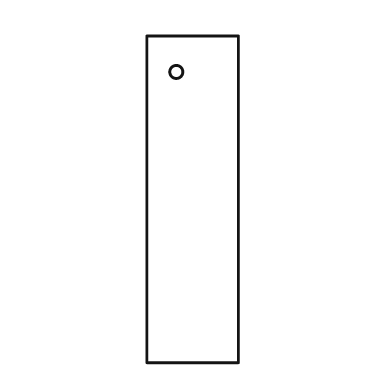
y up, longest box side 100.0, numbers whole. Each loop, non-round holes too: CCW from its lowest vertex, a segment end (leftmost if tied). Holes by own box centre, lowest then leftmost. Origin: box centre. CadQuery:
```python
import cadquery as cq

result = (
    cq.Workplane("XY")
    .moveTo(-14.0, -50.0)
    .lineTo(14.0, -50.0)
    .lineTo(14.0, 50.0)
    .lineTo(-14.0, 50.0)
    .close()
    .moveTo(-5.0, 39.0)
    .circle(2.0)
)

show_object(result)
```